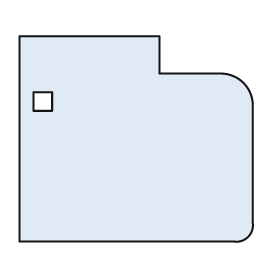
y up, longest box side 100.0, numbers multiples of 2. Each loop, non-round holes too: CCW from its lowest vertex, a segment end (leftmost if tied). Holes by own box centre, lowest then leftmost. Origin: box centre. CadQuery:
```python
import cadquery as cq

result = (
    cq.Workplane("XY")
    .moveTo(-50.0, -44.0)
    .lineTo(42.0, -44.0)
    .threePointArc((48.0, -42.0), (50.0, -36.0))
    .lineTo(50.0, 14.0)
    .threePointArc((46.0, 24.0), (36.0, 28.0))
    .lineTo(10.0, 28.0)
    .lineTo(10.0, 44.0)
    .lineTo(-50.0, 44.0)
    .close()
    .moveTo(-44.0, 12.0)
    .lineTo(-36.0, 12.0)
    .lineTo(-36.0, 20.0)
    .lineTo(-44.0, 20.0)
    .close()
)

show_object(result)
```